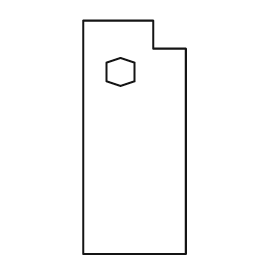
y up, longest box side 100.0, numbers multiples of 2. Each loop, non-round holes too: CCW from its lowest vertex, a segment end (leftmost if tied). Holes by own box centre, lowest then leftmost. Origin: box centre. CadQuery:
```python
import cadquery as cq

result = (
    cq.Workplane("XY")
    .moveTo(-22.0, -50.0)
    .lineTo(22.0, -50.0)
    .lineTo(22.0, 38.0)
    .lineTo(8.0, 38.0)
    .lineTo(8.0, 50.0)
    .lineTo(-22.0, 50.0)
    .close()
    .moveTo(-6.0, 22.0)
    .lineTo(0.0, 24.0)
    .lineTo(0.0, 32.0)
    .lineTo(-6.0, 34.0)
    .lineTo(-12.0, 32.0)
    .lineTo(-12.0, 24.0)
    .close()
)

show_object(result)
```